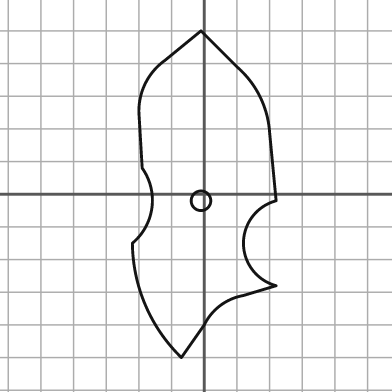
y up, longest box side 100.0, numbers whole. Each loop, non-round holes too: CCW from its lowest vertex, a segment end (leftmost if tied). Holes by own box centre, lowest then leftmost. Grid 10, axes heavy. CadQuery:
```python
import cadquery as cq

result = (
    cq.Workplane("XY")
    .moveTo(-7.0, -50.0)
    .lineTo(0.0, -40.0)
    .threePointArc((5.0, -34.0), (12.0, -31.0))
    .lineTo(22.0, -28.0)
    .threePointArc((12.0, -15.0), (22.0, -2.0))
    .lineTo(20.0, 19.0)
    .threePointArc((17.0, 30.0), (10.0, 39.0))
    .lineTo(-1.0, 50.0)
    .lineTo(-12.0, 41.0)
    .threePointArc((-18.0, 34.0), (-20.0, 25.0))
    .lineTo(-19.0, 8.0)
    .threePointArc((-16.0, -4.0), (-22.0, -15.0))
    .threePointArc((-18.0, -34.0), (-7.0, -50.0))
    .close()
    .moveTo(-1.0, -2.0)
    .circle(3.0)
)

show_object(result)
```